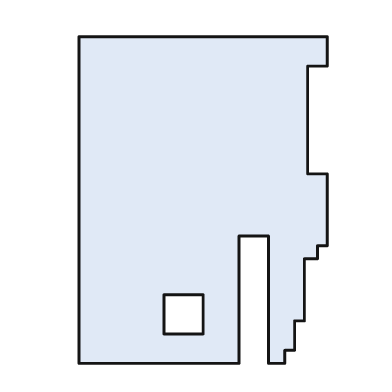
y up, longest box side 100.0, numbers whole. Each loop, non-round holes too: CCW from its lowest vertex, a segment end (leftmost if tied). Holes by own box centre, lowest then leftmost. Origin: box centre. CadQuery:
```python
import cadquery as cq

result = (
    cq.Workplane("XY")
    .moveTo(-38.0, -50.0)
    .lineTo(11.0, -50.0)
    .lineTo(11.0, -11.0)
    .lineTo(20.0, -11.0)
    .lineTo(20.0, -50.0)
    .lineTo(25.0, -50.0)
    .lineTo(25.0, -46.0)
    .lineTo(28.0, -46.0)
    .lineTo(28.0, -37.0)
    .lineTo(31.0, -37.0)
    .lineTo(31.0, -18.0)
    .lineTo(35.0, -18.0)
    .lineTo(35.0, -14.0)
    .lineTo(38.0, -14.0)
    .lineTo(38.0, 8.0)
    .lineTo(32.0, 8.0)
    .lineTo(32.0, 41.0)
    .lineTo(38.0, 41.0)
    .lineTo(38.0, 50.0)
    .lineTo(-38.0, 50.0)
    .close()
    .moveTo(-12.0, -41.0)
    .lineTo(0.0, -41.0)
    .lineTo(0.0, -29.0)
    .lineTo(-12.0, -29.0)
    .close()
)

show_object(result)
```